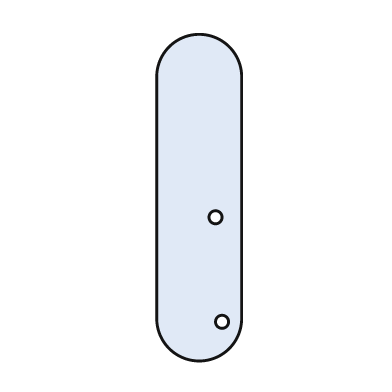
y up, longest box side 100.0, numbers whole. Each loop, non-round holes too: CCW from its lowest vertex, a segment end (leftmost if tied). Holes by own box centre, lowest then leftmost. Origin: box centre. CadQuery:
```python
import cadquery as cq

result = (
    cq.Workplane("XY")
    .moveTo(-13.0, -37.0)
    .threePointArc((0.0, -50.0), (13.0, -37.0))
    .lineTo(13.0, 37.0)
    .threePointArc((0.0, 50.0), (-13.0, 37.0))
    .close()
    .moveTo(7.0, -38.0)
    .circle(2.0)
    .moveTo(5.0, -6.0)
    .circle(2.0)
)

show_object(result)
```